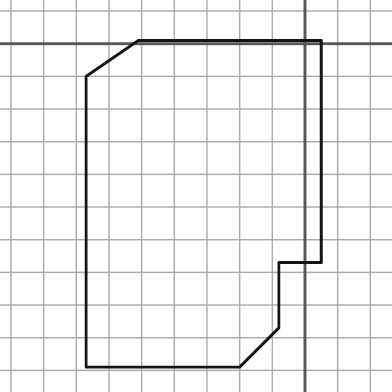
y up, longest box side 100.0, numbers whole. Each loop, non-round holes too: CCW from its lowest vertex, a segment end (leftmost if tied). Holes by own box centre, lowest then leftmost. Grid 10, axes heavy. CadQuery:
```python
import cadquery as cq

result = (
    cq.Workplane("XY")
    .moveTo(-67.0, -99.0)
    .lineTo(-20.0, -99.0)
    .lineTo(-8.0, -87.0)
    .lineTo(-8.0, -67.0)
    .lineTo(5.0, -67.0)
    .lineTo(5.0, 1.0)
    .lineTo(-51.0, 1.0)
    .lineTo(-67.0, -10.0)
    .close()
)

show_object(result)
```